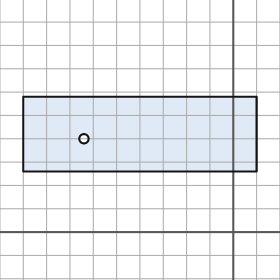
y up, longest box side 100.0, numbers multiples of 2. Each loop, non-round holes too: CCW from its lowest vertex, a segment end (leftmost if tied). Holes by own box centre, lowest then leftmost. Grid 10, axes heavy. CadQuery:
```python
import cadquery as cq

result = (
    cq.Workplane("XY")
    .moveTo(-90.0, 26.0)
    .lineTo(10.0, 26.0)
    .lineTo(10.0, 58.0)
    .lineTo(-90.0, 58.0)
    .close()
    .moveTo(-64.0, 40.0)
    .circle(2.0)
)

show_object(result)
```